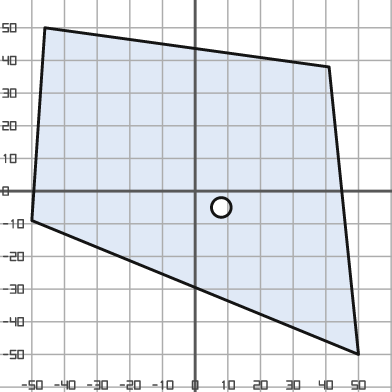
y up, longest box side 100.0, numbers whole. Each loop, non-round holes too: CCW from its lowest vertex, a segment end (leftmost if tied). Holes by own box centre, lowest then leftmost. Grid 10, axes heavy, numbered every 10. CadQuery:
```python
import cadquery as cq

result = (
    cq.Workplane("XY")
    .moveTo(50.0, -50.0)
    .lineTo(41.0, 38.0)
    .lineTo(-46.0, 50.0)
    .lineTo(-50.0, -9.0)
    .close()
    .moveTo(8.0, -5.0)
    .circle(3.0)
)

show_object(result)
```